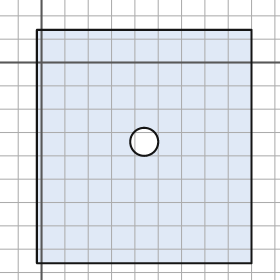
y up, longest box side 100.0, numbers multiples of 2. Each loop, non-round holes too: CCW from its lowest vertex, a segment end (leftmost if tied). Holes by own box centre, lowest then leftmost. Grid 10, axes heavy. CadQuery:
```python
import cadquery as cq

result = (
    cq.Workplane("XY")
    .moveTo(-2.0, -86.0)
    .lineTo(90.0, -86.0)
    .lineTo(90.0, 14.0)
    .lineTo(-2.0, 14.0)
    .close()
    .moveTo(44.0, -34.0)
    .circle(6.0)
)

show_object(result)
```